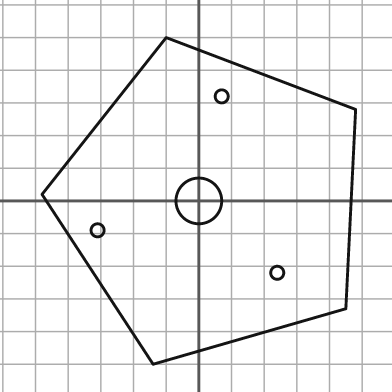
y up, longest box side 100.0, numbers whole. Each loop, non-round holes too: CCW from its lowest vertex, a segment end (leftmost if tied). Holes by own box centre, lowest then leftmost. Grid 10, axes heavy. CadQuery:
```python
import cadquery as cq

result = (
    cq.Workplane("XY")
    .moveTo(-14.0, -50.0)
    .lineTo(45.0, -33.0)
    .lineTo(48.0, 28.0)
    .lineTo(-10.0, 50.0)
    .lineTo(-48.0, 2.0)
    .close()
    .moveTo(24.0, -22.0)
    .circle(2.0)
    .moveTo(-31.0, -9.0)
    .circle(2.0)
    .moveTo(0.0, 0.0)
    .circle(7.0)
    .moveTo(7.0, 32.0)
    .circle(2.0)
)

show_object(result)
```